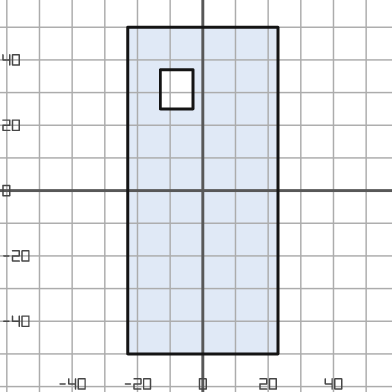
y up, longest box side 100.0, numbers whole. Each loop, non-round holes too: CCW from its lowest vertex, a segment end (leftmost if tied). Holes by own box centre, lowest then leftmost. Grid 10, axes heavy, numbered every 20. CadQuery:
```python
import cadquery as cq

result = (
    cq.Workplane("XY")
    .moveTo(-23.0, -50.0)
    .lineTo(23.0, -50.0)
    .lineTo(23.0, 50.0)
    .lineTo(-23.0, 50.0)
    .close()
    .moveTo(-13.0, 25.0)
    .lineTo(-3.0, 25.0)
    .lineTo(-3.0, 37.0)
    .lineTo(-13.0, 37.0)
    .close()
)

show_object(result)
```